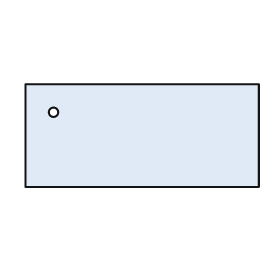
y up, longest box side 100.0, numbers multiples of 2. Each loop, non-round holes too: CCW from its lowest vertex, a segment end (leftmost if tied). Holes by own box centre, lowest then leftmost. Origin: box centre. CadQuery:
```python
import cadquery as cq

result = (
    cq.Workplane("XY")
    .moveTo(-50.0, -22.0)
    .lineTo(50.0, -22.0)
    .lineTo(50.0, 22.0)
    .lineTo(-50.0, 22.0)
    .close()
    .moveTo(-38.0, 10.0)
    .circle(2.0)
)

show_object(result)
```